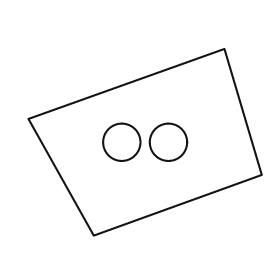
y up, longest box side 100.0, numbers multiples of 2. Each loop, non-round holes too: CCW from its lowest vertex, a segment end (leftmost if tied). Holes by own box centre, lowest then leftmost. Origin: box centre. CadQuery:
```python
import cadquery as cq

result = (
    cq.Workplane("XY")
    .moveTo(-22.0, -40.0)
    .lineTo(50.0, -14.0)
    .lineTo(34.0, 40.0)
    .lineTo(-50.0, 10.0)
    .close()
    .moveTo(-10.0, 0.0)
    .circle(8.0)
    .moveTo(10.0, 0.0)
    .circle(8.0)
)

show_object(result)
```